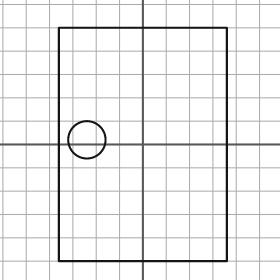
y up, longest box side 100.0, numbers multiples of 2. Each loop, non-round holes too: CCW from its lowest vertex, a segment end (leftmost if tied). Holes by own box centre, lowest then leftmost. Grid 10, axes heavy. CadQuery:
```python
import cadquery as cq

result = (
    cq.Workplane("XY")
    .moveTo(-36.0, -50.0)
    .lineTo(36.0, -50.0)
    .lineTo(36.0, 50.0)
    .lineTo(-36.0, 50.0)
    .close()
    .moveTo(-24.0, 2.0)
    .circle(8.0)
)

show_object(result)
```